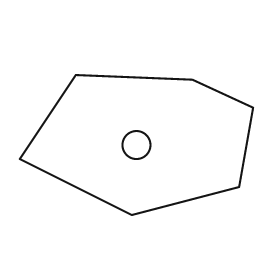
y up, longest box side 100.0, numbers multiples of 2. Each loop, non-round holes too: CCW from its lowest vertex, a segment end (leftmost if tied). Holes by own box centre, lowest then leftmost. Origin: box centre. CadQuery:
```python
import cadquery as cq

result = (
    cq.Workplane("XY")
    .moveTo(-2.0, -30.0)
    .lineTo(44.0, -18.0)
    .lineTo(50.0, 16.0)
    .lineTo(24.0, 28.0)
    .lineTo(-26.0, 30.0)
    .lineTo(-50.0, -6.0)
    .close()
    .moveTo(0.0, 0.0)
    .circle(6.0)
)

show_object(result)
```